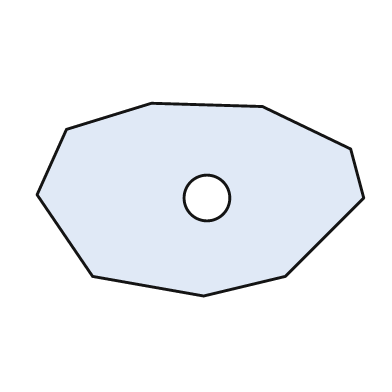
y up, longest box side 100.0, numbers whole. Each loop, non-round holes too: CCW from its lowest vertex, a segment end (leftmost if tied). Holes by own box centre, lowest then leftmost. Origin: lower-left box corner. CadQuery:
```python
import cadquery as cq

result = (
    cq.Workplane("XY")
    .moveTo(51.0, 0.0)
    .lineTo(76.0, 6.0)
    .lineTo(100.0, 30.0)
    .lineTo(96.0, 45.0)
    .lineTo(69.0, 58.0)
    .lineTo(35.0, 59.0)
    .lineTo(9.0, 51.0)
    .lineTo(0.0, 31.0)
    .lineTo(17.0, 6.0)
    .close()
    .moveTo(52.0, 30.0)
    .circle(7.0)
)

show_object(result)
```